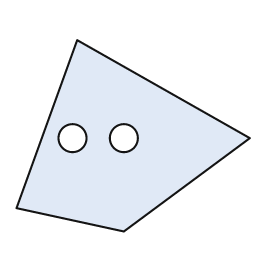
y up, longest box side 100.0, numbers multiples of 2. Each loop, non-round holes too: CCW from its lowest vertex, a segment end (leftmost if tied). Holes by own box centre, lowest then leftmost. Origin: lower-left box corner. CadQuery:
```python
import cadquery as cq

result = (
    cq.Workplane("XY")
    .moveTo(46.0, 0.0)
    .lineTo(100.0, 40.0)
    .lineTo(26.0, 82.0)
    .lineTo(0.0, 10.0)
    .close()
    .moveTo(24.0, 40.0)
    .circle(6.0)
    .moveTo(46.0, 40.0)
    .circle(6.0)
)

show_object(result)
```